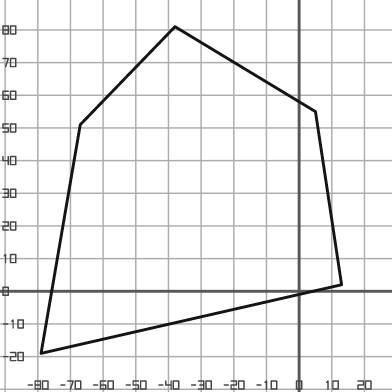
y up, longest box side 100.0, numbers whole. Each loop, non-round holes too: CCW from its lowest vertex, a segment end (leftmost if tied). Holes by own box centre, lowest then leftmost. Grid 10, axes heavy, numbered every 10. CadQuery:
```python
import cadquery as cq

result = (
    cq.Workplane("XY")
    .moveTo(-79.0, -19.0)
    .lineTo(13.0, 2.0)
    .lineTo(5.0, 55.0)
    .lineTo(-38.0, 81.0)
    .lineTo(-67.0, 51.0)
    .close()
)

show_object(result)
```